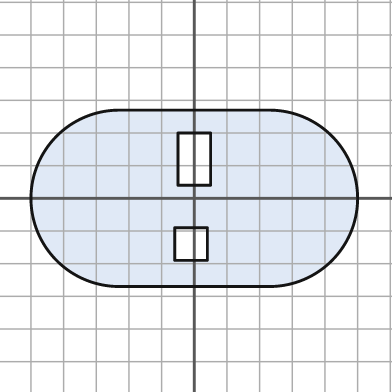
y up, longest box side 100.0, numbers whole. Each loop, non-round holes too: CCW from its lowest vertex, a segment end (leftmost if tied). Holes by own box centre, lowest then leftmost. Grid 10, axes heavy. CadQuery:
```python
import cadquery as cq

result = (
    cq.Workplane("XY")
    .moveTo(-23.0, -27.0)
    .lineTo(23.0, -27.0)
    .threePointArc((50.0, 0.0), (23.0, 27.0))
    .lineTo(-23.0, 27.0)
    .threePointArc((-50.0, 0.0), (-23.0, -27.0))
    .close()
    .moveTo(-6.0, -19.0)
    .lineTo(4.0, -19.0)
    .lineTo(4.0, -9.0)
    .lineTo(-6.0, -9.0)
    .close()
    .moveTo(-5.0, 4.0)
    .lineTo(5.0, 4.0)
    .lineTo(5.0, 20.0)
    .lineTo(-5.0, 20.0)
    .close()
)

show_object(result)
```